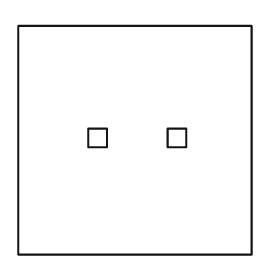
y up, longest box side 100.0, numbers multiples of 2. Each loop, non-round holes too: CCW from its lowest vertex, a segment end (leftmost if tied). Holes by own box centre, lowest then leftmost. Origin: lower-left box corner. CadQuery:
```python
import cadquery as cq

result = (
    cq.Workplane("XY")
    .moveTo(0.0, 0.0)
    .lineTo(100.0, 0.0)
    .lineTo(100.0, 98.0)
    .lineTo(0.0, 98.0)
    .close()
    .moveTo(30.0, 46.0)
    .lineTo(38.0, 46.0)
    .lineTo(38.0, 54.0)
    .lineTo(30.0, 54.0)
    .close()
    .moveTo(64.0, 46.0)
    .lineTo(72.0, 46.0)
    .lineTo(72.0, 54.0)
    .lineTo(64.0, 54.0)
    .close()
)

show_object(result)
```